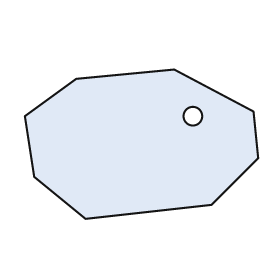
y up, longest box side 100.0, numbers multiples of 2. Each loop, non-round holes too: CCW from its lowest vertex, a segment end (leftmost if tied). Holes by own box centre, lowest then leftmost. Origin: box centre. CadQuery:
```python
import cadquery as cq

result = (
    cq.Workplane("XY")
    .moveTo(-24.0, -32.0)
    .lineTo(30.0, -26.0)
    .lineTo(50.0, -6.0)
    .lineTo(48.0, 14.0)
    .lineTo(14.0, 32.0)
    .lineTo(-28.0, 28.0)
    .lineTo(-50.0, 12.0)
    .lineTo(-46.0, -14.0)
    .close()
    .moveTo(22.0, 12.0)
    .circle(4.0)
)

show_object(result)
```